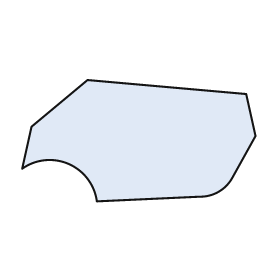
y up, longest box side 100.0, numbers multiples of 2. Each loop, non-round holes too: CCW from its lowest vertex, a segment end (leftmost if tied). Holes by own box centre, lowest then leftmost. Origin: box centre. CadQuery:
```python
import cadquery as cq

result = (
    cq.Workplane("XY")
    .moveTo(-18.0, -26.0)
    .lineTo(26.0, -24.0)
    .threePointArc((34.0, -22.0), (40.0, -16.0))
    .lineTo(50.0, 2.0)
    .lineTo(46.0, 20.0)
    .lineTo(-22.0, 26.0)
    .lineTo(-46.0, 6.0)
    .lineTo(-50.0, -12.0)
    .threePointArc((-30.0, -10.0), (-18.0, -26.0))
    .close()
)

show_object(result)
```